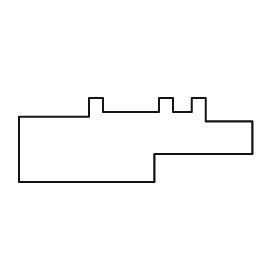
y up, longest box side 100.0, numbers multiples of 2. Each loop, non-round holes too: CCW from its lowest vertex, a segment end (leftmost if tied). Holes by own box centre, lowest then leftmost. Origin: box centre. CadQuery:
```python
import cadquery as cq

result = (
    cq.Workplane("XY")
    .moveTo(-50.0, -18.0)
    .lineTo(8.0, -18.0)
    .lineTo(8.0, -6.0)
    .lineTo(50.0, -6.0)
    .lineTo(50.0, 8.0)
    .lineTo(30.0, 8.0)
    .lineTo(30.0, 18.0)
    .lineTo(24.0, 18.0)
    .lineTo(24.0, 12.0)
    .lineTo(16.0, 12.0)
    .lineTo(16.0, 18.0)
    .lineTo(10.0, 18.0)
    .lineTo(10.0, 12.0)
    .lineTo(-14.0, 12.0)
    .lineTo(-14.0, 18.0)
    .lineTo(-20.0, 18.0)
    .lineTo(-20.0, 10.0)
    .lineTo(-50.0, 10.0)
    .close()
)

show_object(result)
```